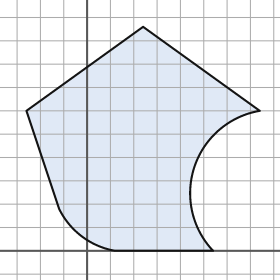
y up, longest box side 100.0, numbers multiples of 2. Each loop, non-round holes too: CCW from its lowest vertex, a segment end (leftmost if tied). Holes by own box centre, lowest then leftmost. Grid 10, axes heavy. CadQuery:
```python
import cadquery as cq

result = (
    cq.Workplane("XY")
    .moveTo(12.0, 0.0)
    .lineTo(54.0, 0.0)
    .threePointArc((46.0, 36.0), (74.0, 60.0))
    .lineTo(24.0, 96.0)
    .lineTo(-26.0, 60.0)
    .lineTo(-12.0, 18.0)
    .threePointArc((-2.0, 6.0), (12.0, 0.0))
    .close()
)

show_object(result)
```